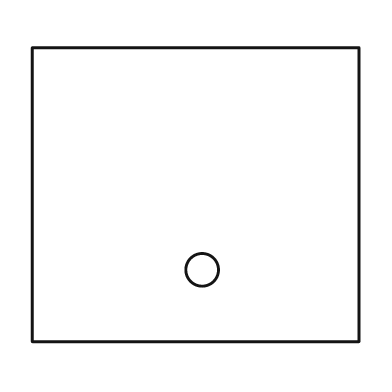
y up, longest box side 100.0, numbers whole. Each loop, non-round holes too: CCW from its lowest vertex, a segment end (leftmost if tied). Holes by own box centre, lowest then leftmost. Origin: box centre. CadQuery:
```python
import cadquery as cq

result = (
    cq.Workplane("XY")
    .moveTo(-50.0, -45.0)
    .lineTo(50.0, -45.0)
    .lineTo(50.0, 45.0)
    .lineTo(-50.0, 45.0)
    .close()
    .moveTo(2.0, -23.0)
    .circle(5.0)
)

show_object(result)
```